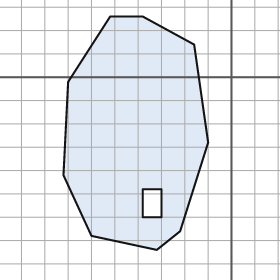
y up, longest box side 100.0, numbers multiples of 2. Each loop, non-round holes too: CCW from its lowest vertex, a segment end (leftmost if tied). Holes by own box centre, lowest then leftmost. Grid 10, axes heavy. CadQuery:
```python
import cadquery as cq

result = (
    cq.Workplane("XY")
    .moveTo(-32.0, -74.0)
    .lineTo(-22.0, -66.0)
    .lineTo(-10.0, -28.0)
    .lineTo(-16.0, 14.0)
    .lineTo(-38.0, 26.0)
    .lineTo(-52.0, 26.0)
    .lineTo(-70.0, -2.0)
    .lineTo(-72.0, -42.0)
    .lineTo(-60.0, -68.0)
    .close()
    .moveTo(-38.0, -60.0)
    .lineTo(-30.0, -60.0)
    .lineTo(-30.0, -48.0)
    .lineTo(-38.0, -48.0)
    .close()
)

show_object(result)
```